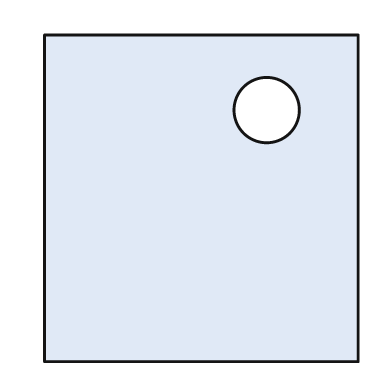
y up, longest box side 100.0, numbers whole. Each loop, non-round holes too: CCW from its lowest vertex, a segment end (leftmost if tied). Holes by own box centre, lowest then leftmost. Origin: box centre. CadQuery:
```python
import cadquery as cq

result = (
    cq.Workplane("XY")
    .moveTo(-48.0, -50.0)
    .lineTo(48.0, -50.0)
    .lineTo(48.0, 50.0)
    .lineTo(-48.0, 50.0)
    .close()
    .moveTo(20.0, 27.0)
    .circle(10.0)
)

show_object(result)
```